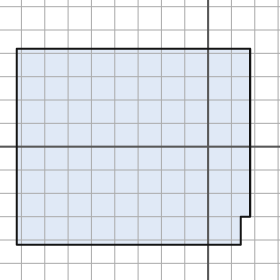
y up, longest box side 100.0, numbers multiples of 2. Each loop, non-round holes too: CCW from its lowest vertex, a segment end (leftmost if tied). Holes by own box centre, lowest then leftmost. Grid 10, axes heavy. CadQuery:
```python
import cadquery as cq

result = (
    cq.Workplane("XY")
    .moveTo(-82.0, -42.0)
    .lineTo(14.0, -42.0)
    .lineTo(14.0, -30.0)
    .lineTo(18.0, -30.0)
    .lineTo(18.0, 42.0)
    .lineTo(-82.0, 42.0)
    .close()
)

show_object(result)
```